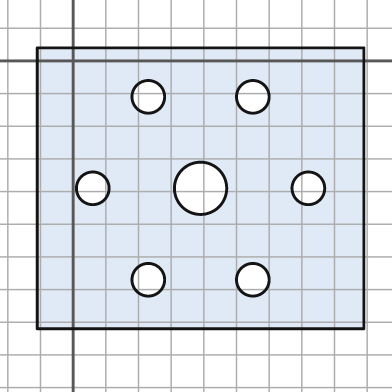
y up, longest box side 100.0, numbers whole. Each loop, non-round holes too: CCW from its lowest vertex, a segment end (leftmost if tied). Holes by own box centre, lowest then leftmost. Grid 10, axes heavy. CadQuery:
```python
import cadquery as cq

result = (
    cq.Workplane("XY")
    .moveTo(-11.0, -82.0)
    .lineTo(89.0, -82.0)
    .lineTo(89.0, 4.0)
    .lineTo(-11.0, 4.0)
    .close()
    .moveTo(23.0, -67.0)
    .circle(5.0)
    .moveTo(55.0, -67.0)
    .circle(5.0)
    .moveTo(6.0, -39.0)
    .circle(5.0)
    .moveTo(39.0, -39.0)
    .circle(8.0)
    .moveTo(72.0, -39.0)
    .circle(5.0)
    .moveTo(23.0, -11.0)
    .circle(5.0)
    .moveTo(55.0, -11.0)
    .circle(5.0)
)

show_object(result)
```